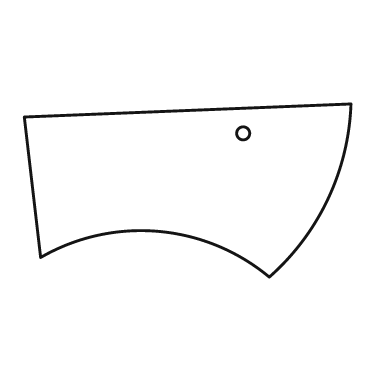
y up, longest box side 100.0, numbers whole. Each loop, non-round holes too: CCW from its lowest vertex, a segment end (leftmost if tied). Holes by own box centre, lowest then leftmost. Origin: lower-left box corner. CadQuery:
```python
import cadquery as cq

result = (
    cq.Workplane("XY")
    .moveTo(75.0, 0.0)
    .threePointArc((93.0, 24.0), (100.0, 53.0))
    .lineTo(0.0, 49.0)
    .lineTo(5.0, 6.0)
    .threePointArc((41.0, 14.0), (75.0, 0.0))
    .close()
    .moveTo(67.0, 44.0)
    .circle(2.0)
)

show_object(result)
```